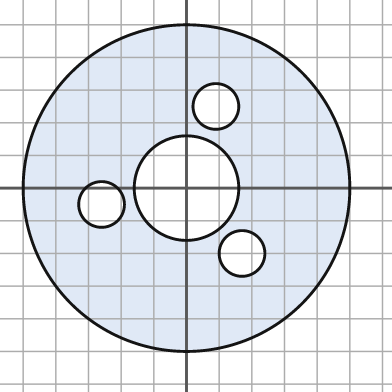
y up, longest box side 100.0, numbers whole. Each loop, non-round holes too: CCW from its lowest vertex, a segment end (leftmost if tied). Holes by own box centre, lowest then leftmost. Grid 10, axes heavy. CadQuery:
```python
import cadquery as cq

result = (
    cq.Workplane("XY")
    .moveTo(0.0, 0.0)
    .circle(50.0)
    .moveTo(17.0, -20.0)
    .circle(7.0)
    .moveTo(-26.0, -5.0)
    .circle(7.0)
    .moveTo(0.0, 0.0)
    .circle(16.0)
    .moveTo(9.0, 25.0)
    .circle(7.0)
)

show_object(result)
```